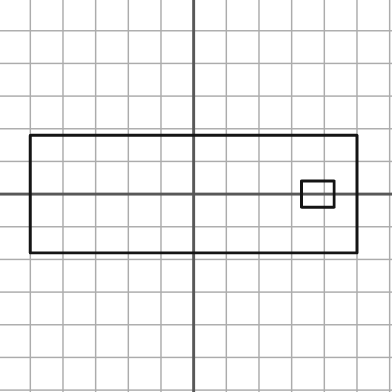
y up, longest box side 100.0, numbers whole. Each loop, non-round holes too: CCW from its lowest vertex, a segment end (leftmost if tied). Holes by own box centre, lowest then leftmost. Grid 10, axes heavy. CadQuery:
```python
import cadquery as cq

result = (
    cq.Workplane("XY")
    .moveTo(-50.0, -18.0)
    .lineTo(50.0, -18.0)
    .lineTo(50.0, 18.0)
    .lineTo(-50.0, 18.0)
    .close()
    .moveTo(33.0, -4.0)
    .lineTo(43.0, -4.0)
    .lineTo(43.0, 4.0)
    .lineTo(33.0, 4.0)
    .close()
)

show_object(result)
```